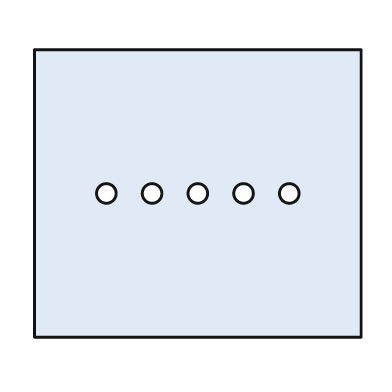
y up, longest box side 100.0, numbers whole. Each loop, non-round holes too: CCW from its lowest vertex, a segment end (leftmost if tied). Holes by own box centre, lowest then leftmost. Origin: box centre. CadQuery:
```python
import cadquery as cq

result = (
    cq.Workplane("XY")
    .moveTo(-50.0, -44.0)
    .lineTo(50.0, -44.0)
    .lineTo(50.0, 44.0)
    .lineTo(-50.0, 44.0)
    .close()
    .moveTo(-28.0, 0.0)
    .circle(3.0)
    .moveTo(-14.0, 0.0)
    .circle(3.0)
    .moveTo(0.0, 0.0)
    .circle(3.0)
    .moveTo(14.0, 0.0)
    .circle(3.0)
    .moveTo(28.0, 0.0)
    .circle(3.0)
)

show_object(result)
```